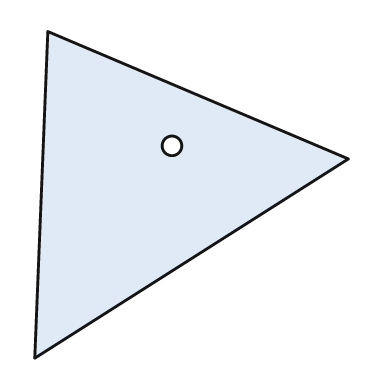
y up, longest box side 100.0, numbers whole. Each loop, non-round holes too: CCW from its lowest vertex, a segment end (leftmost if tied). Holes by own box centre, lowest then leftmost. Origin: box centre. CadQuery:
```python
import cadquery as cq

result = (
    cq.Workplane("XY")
    .moveTo(-48.0, -50.0)
    .lineTo(48.0, 11.0)
    .lineTo(-44.0, 50.0)
    .close()
    .moveTo(-6.0, 15.0)
    .circle(3.0)
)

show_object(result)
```